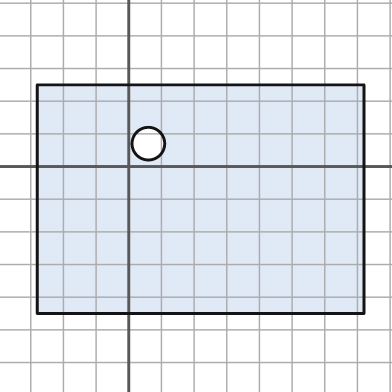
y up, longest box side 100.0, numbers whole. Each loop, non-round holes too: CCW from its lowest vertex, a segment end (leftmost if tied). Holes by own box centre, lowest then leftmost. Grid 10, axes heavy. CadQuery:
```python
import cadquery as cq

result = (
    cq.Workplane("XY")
    .moveTo(-28.0, -45.0)
    .lineTo(72.0, -45.0)
    .lineTo(72.0, 25.0)
    .lineTo(-28.0, 25.0)
    .close()
    .moveTo(6.0, 7.0)
    .circle(5.0)
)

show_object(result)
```